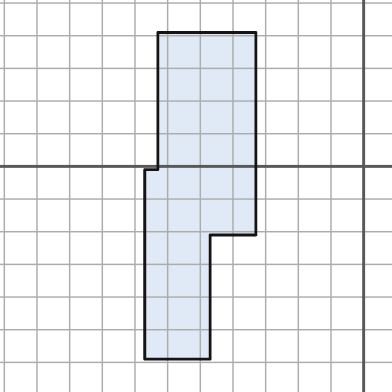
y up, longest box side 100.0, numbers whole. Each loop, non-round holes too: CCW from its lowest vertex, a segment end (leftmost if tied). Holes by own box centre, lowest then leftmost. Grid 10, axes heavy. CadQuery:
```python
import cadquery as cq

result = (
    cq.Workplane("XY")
    .moveTo(-67.0, -59.0)
    .lineTo(-47.0, -59.0)
    .lineTo(-47.0, -21.0)
    .lineTo(-33.0, -21.0)
    .lineTo(-33.0, 41.0)
    .lineTo(-63.0, 41.0)
    .lineTo(-63.0, -1.0)
    .lineTo(-67.0, -1.0)
    .close()
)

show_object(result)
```